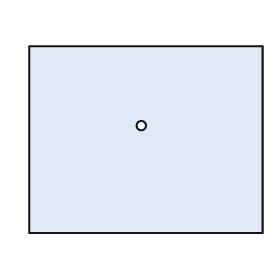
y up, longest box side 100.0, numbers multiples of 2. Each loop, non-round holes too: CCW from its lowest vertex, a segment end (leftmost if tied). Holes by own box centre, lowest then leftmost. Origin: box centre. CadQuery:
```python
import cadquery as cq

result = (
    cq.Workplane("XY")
    .moveTo(-50.0, -40.0)
    .lineTo(50.0, -40.0)
    .lineTo(50.0, 40.0)
    .lineTo(-50.0, 40.0)
    .close()
    .moveTo(-2.0, 6.0)
    .circle(2.0)
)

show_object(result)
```